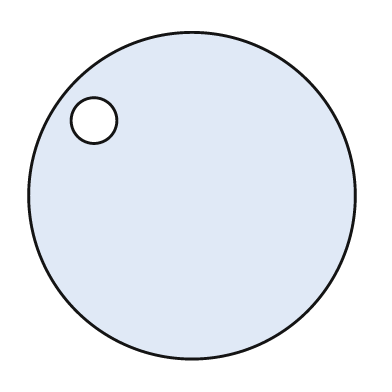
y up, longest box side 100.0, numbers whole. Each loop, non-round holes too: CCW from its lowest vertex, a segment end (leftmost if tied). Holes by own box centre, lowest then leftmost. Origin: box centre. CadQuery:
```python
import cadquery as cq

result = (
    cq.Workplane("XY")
    .moveTo(0.0, 0.0)
    .circle(50.0)
    .moveTo(-30.0, 23.0)
    .circle(7.0)
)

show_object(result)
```